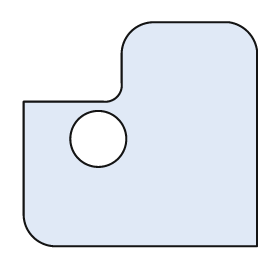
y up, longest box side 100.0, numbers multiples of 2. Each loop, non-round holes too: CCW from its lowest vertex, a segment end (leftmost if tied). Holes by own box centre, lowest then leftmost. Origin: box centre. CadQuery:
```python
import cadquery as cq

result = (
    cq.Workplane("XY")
    .moveTo(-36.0, -48.0)
    .lineTo(50.0, -48.0)
    .lineTo(50.0, 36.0)
    .threePointArc((46.0, 44.0), (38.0, 48.0))
    .lineTo(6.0, 48.0)
    .threePointArc((-4.0, 44.0), (-8.0, 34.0))
    .lineTo(-8.0, 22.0)
    .threePointArc((-10.0, 16.0), (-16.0, 14.0))
    .lineTo(-50.0, 14.0)
    .lineTo(-50.0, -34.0)
    .threePointArc((-46.0, -44.0), (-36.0, -48.0))
    .close()
    .moveTo(-18.0, -2.0)
    .circle(12.0)
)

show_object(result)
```